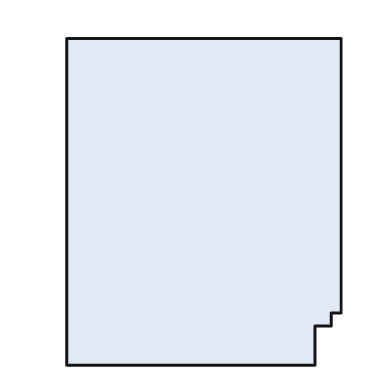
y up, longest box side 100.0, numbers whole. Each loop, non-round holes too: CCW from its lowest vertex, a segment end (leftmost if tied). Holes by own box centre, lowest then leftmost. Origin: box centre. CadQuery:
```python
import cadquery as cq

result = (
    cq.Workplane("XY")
    .moveTo(-42.0, -50.0)
    .lineTo(34.0, -50.0)
    .lineTo(34.0, -38.0)
    .lineTo(39.0, -38.0)
    .lineTo(39.0, -34.0)
    .lineTo(42.0, -34.0)
    .lineTo(42.0, 50.0)
    .lineTo(-42.0, 50.0)
    .close()
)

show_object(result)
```